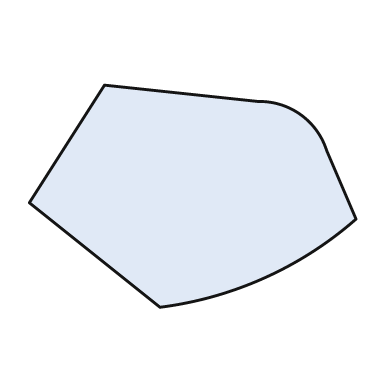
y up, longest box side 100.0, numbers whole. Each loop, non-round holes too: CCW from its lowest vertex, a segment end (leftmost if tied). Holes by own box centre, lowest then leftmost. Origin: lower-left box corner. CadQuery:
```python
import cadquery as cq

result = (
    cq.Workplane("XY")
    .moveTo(40.0, 0.0)
    .threePointArc((72.0, 9.0), (100.0, 27.0))
    .lineTo(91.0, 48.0)
    .threePointArc((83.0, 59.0), (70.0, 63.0))
    .lineTo(23.0, 68.0)
    .lineTo(0.0, 32.0)
    .close()
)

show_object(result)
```